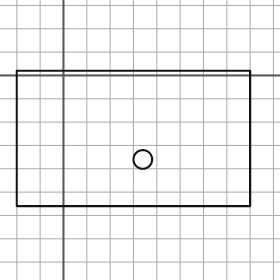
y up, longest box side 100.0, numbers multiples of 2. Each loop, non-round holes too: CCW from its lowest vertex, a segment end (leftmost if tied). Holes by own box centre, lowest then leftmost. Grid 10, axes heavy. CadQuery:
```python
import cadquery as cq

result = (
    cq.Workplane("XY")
    .moveTo(-20.0, -56.0)
    .lineTo(80.0, -56.0)
    .lineTo(80.0, 2.0)
    .lineTo(-20.0, 2.0)
    .close()
    .moveTo(34.0, -36.0)
    .circle(4.0)
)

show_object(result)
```